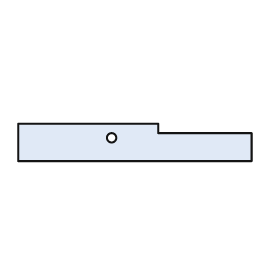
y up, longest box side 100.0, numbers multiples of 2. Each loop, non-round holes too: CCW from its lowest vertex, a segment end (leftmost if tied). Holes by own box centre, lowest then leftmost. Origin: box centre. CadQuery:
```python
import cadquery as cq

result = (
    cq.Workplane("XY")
    .moveTo(-50.0, -8.0)
    .lineTo(50.0, -8.0)
    .lineTo(50.0, 4.0)
    .lineTo(10.0, 4.0)
    .lineTo(10.0, 8.0)
    .lineTo(-50.0, 8.0)
    .close()
    .moveTo(-10.0, 2.0)
    .circle(2.0)
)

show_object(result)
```